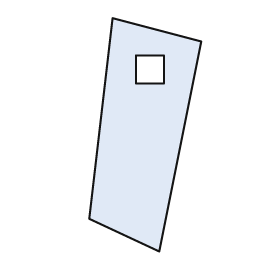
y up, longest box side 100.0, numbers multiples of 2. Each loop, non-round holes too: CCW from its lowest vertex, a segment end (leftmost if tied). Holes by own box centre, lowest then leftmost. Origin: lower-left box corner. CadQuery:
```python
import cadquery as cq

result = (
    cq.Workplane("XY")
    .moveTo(30.0, 0.0)
    .lineTo(48.0, 90.0)
    .lineTo(10.0, 100.0)
    .lineTo(0.0, 14.0)
    .close()
    .moveTo(20.0, 72.0)
    .lineTo(32.0, 72.0)
    .lineTo(32.0, 84.0)
    .lineTo(20.0, 84.0)
    .close()
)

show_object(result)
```